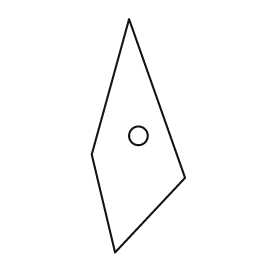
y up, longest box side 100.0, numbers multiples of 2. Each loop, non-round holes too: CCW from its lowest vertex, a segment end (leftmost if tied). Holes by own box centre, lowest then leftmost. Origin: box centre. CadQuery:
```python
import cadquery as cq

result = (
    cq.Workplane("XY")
    .moveTo(-10.0, -50.0)
    .lineTo(20.0, -18.0)
    .lineTo(-4.0, 50.0)
    .lineTo(-20.0, -8.0)
    .close()
    .moveTo(0.0, 0.0)
    .circle(4.0)
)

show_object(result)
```